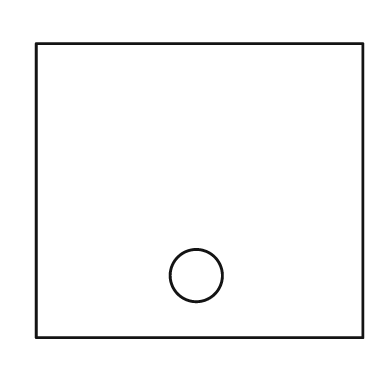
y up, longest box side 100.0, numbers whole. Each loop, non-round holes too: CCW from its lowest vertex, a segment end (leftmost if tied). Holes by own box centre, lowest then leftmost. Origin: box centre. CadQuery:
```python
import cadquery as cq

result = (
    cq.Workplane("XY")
    .moveTo(-50.0, -45.0)
    .lineTo(50.0, -45.0)
    .lineTo(50.0, 45.0)
    .lineTo(-50.0, 45.0)
    .close()
    .moveTo(-1.0, -26.0)
    .circle(8.0)
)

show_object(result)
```